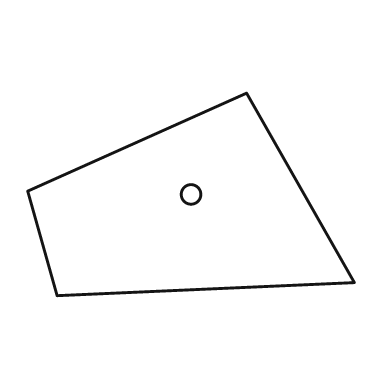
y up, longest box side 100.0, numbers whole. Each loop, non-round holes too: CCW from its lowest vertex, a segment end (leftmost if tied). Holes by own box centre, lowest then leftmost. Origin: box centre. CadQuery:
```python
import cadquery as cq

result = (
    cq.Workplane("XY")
    .moveTo(-41.0, -31.0)
    .lineTo(50.0, -27.0)
    .lineTo(17.0, 31.0)
    .lineTo(-50.0, 1.0)
    .close()
    .moveTo(0.0, 0.0)
    .circle(3.0)
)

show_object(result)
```